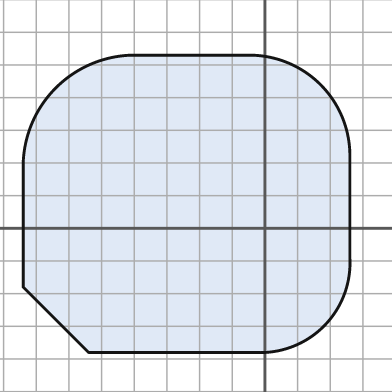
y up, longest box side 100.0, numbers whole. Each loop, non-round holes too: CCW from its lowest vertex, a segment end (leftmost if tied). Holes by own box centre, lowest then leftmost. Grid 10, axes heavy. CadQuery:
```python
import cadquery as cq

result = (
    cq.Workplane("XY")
    .moveTo(-54.0, -38.0)
    .lineTo(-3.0, -38.0)
    .threePointArc((18.0, -30.0), (26.0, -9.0))
    .lineTo(26.0, 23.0)
    .threePointArc((17.0, 44.0), (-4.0, 53.0))
    .lineTo(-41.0, 53.0)
    .threePointArc((-64.0, 43.0), (-74.0, 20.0))
    .lineTo(-74.0, -18.0)
    .close()
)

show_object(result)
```